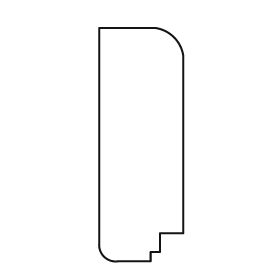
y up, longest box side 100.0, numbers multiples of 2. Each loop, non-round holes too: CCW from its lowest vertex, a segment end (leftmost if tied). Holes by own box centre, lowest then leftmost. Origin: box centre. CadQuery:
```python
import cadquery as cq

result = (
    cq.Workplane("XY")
    .moveTo(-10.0, -50.0)
    .lineTo(4.0, -50.0)
    .lineTo(4.0, -46.0)
    .lineTo(8.0, -46.0)
    .lineTo(8.0, -38.0)
    .lineTo(18.0, -38.0)
    .lineTo(18.0, 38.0)
    .threePointArc((14.0, 46.0), (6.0, 50.0))
    .lineTo(-18.0, 50.0)
    .lineTo(-18.0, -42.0)
    .threePointArc((-16.0, -48.0), (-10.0, -50.0))
    .close()
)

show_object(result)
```